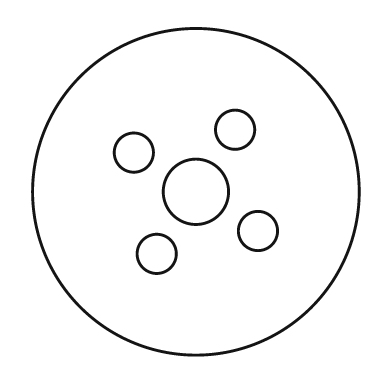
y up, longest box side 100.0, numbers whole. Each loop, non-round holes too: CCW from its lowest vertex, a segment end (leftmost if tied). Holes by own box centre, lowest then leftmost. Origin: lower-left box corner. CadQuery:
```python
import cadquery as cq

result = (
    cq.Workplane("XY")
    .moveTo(50.0, 50.0)
    .circle(50.0)
    .moveTo(38.0, 31.0)
    .circle(6.0)
    .moveTo(69.0, 38.0)
    .circle(6.0)
    .moveTo(50.0, 50.0)
    .circle(10.0)
    .moveTo(31.0, 62.0)
    .circle(6.0)
    .moveTo(62.0, 69.0)
    .circle(6.0)
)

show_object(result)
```